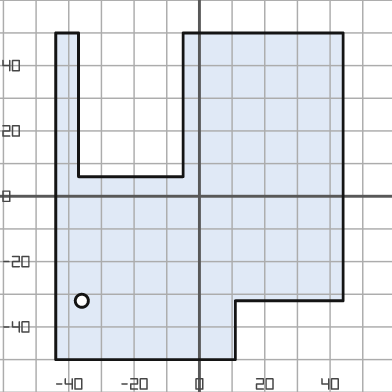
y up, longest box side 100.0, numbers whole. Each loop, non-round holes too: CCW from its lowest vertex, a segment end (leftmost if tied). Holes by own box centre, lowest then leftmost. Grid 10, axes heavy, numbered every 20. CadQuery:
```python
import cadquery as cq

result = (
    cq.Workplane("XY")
    .moveTo(-44.0, -50.0)
    .lineTo(11.0, -50.0)
    .lineTo(11.0, -32.0)
    .lineTo(44.0, -32.0)
    .lineTo(44.0, 50.0)
    .lineTo(-5.0, 50.0)
    .lineTo(-5.0, 6.0)
    .lineTo(-37.0, 6.0)
    .lineTo(-37.0, 50.0)
    .lineTo(-44.0, 50.0)
    .close()
    .moveTo(-36.0, -32.0)
    .circle(2.0)
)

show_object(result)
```